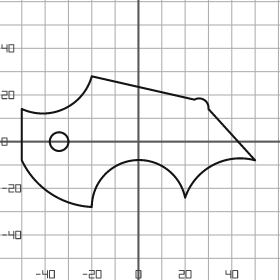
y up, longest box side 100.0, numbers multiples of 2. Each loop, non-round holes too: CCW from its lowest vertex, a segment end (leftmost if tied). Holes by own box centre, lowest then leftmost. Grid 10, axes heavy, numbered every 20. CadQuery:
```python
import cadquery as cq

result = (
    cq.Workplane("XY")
    .moveTo(-20.0, -28.0)
    .threePointArc((-2.0, -8.0), (20.0, -24.0))
    .threePointArc((32.0, -10.0), (50.0, -8.0))
    .lineTo(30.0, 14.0)
    .threePointArc((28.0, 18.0), (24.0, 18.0))
    .lineTo(-20.0, 28.0)
    .threePointArc((-32.0, 14.0), (-50.0, 14.0))
    .lineTo(-50.0, -8.0)
    .threePointArc((-38.0, -22.0), (-20.0, -28.0))
    .close()
    .moveTo(-34.0, 0.0)
    .circle(4.0)
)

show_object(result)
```